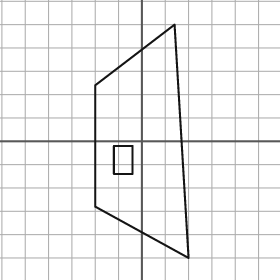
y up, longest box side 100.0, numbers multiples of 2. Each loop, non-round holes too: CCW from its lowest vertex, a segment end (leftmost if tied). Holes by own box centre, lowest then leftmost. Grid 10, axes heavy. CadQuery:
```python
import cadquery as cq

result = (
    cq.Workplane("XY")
    .moveTo(20.0, -50.0)
    .lineTo(14.0, 50.0)
    .lineTo(-20.0, 24.0)
    .lineTo(-20.0, -28.0)
    .close()
    .moveTo(-12.0, -14.0)
    .lineTo(-4.0, -14.0)
    .lineTo(-4.0, -2.0)
    .lineTo(-12.0, -2.0)
    .close()
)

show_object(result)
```